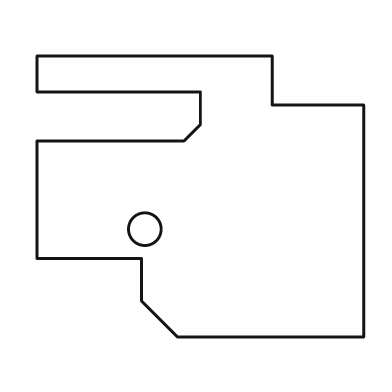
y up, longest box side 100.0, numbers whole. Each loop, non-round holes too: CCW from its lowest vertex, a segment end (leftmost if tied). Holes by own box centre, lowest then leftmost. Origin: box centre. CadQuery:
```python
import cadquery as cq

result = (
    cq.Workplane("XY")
    .moveTo(-7.0, -43.0)
    .lineTo(50.0, -43.0)
    .lineTo(50.0, 28.0)
    .lineTo(22.0, 28.0)
    .lineTo(22.0, 43.0)
    .lineTo(-50.0, 43.0)
    .lineTo(-50.0, 32.0)
    .lineTo(0.0, 32.0)
    .lineTo(0.0, 22.0)
    .lineTo(-5.0, 17.0)
    .lineTo(-50.0, 17.0)
    .lineTo(-50.0, -19.0)
    .lineTo(-18.0, -19.0)
    .lineTo(-18.0, -32.0)
    .close()
    .moveTo(-17.0, -10.0)
    .circle(5.0)
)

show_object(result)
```